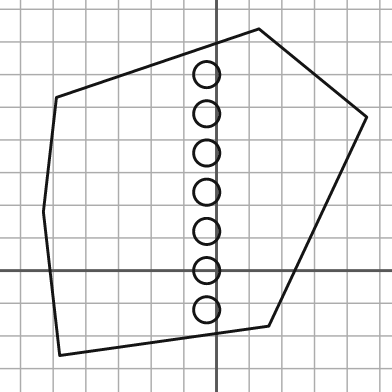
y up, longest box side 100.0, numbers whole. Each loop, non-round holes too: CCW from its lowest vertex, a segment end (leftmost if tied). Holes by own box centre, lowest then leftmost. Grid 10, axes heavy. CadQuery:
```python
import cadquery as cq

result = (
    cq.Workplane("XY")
    .moveTo(-48.0, -26.0)
    .lineTo(16.0, -17.0)
    .lineTo(46.0, 47.0)
    .lineTo(13.0, 74.0)
    .lineTo(-49.0, 53.0)
    .lineTo(-53.0, 18.0)
    .close()
    .moveTo(-3.0, -12.0)
    .circle(4.0)
    .moveTo(-3.0, 0.0)
    .circle(4.0)
    .moveTo(-3.0, 12.0)
    .circle(4.0)
    .moveTo(-3.0, 24.0)
    .circle(4.0)
    .moveTo(-3.0, 36.0)
    .circle(4.0)
    .moveTo(-3.0, 48.0)
    .circle(4.0)
    .moveTo(-3.0, 60.0)
    .circle(4.0)
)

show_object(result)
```